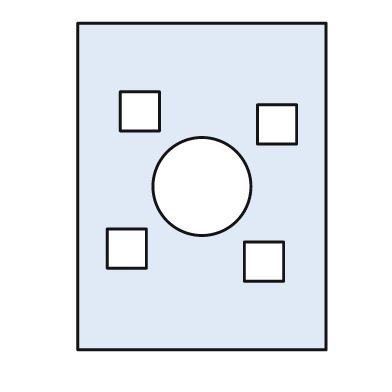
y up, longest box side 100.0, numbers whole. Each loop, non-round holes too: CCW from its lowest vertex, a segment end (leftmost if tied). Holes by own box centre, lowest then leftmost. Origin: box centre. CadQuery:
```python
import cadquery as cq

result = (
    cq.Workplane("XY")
    .moveTo(-38.0, -50.0)
    .lineTo(38.0, -50.0)
    .lineTo(38.0, 50.0)
    .lineTo(-38.0, 50.0)
    .close()
    .moveTo(13.0, -29.0)
    .lineTo(25.0, -29.0)
    .lineTo(25.0, -17.0)
    .lineTo(13.0, -17.0)
    .close()
    .moveTo(-29.0, -25.0)
    .lineTo(-17.0, -25.0)
    .lineTo(-17.0, -13.0)
    .lineTo(-29.0, -13.0)
    .close()
    .moveTo(0.0, 0.0)
    .circle(15.0)
    .moveTo(17.0, 13.0)
    .lineTo(29.0, 13.0)
    .lineTo(29.0, 25.0)
    .lineTo(17.0, 25.0)
    .close()
    .moveTo(-25.0, 17.0)
    .lineTo(-13.0, 17.0)
    .lineTo(-13.0, 29.0)
    .lineTo(-25.0, 29.0)
    .close()
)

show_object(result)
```